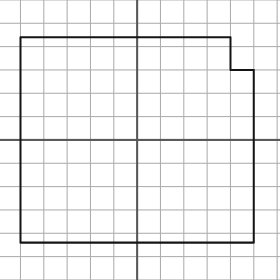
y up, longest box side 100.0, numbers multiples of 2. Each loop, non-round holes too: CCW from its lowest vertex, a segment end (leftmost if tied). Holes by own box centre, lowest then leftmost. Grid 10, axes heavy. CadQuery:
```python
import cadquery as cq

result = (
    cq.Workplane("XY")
    .moveTo(-50.0, -44.0)
    .lineTo(50.0, -44.0)
    .lineTo(50.0, 30.0)
    .lineTo(40.0, 30.0)
    .lineTo(40.0, 44.0)
    .lineTo(-50.0, 44.0)
    .close()
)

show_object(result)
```